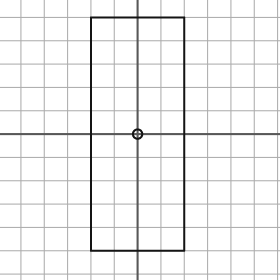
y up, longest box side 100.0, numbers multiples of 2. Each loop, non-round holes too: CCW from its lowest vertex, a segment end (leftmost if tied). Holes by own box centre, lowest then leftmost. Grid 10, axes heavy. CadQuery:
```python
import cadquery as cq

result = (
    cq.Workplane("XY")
    .moveTo(-20.0, -50.0)
    .lineTo(20.0, -50.0)
    .lineTo(20.0, 50.0)
    .lineTo(-20.0, 50.0)
    .close()
    .moveTo(0.0, 0.0)
    .circle(2.0)
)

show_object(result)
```